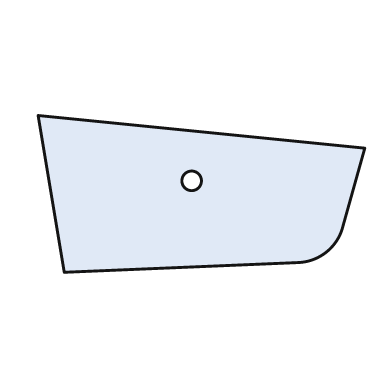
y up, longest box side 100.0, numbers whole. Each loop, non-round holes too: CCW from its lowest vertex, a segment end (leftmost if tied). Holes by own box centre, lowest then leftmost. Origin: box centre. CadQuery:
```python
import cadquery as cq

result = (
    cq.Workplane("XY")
    .moveTo(-42.0, -24.0)
    .lineTo(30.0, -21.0)
    .threePointArc((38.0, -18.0), (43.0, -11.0))
    .lineTo(50.0, 14.0)
    .lineTo(-50.0, 24.0)
    .close()
    .moveTo(-3.0, 4.0)
    .circle(3.0)
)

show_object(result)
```